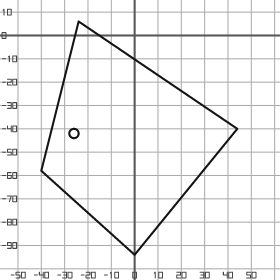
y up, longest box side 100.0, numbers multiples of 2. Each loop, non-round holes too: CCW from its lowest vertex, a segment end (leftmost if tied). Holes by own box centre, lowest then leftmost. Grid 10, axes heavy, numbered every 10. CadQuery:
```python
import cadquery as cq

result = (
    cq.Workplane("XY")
    .moveTo(0.0, -94.0)
    .lineTo(44.0, -40.0)
    .lineTo(-24.0, 6.0)
    .lineTo(-40.0, -58.0)
    .close()
    .moveTo(-26.0, -42.0)
    .circle(2.0)
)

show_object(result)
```